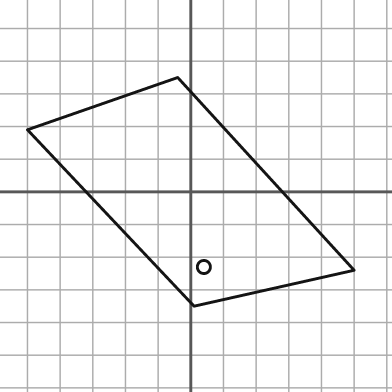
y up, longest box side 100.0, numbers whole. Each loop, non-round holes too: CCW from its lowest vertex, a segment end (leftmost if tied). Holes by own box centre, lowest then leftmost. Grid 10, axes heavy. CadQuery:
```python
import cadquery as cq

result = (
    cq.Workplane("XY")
    .moveTo(1.0, -35.0)
    .lineTo(50.0, -24.0)
    .lineTo(-4.0, 35.0)
    .lineTo(-50.0, 19.0)
    .close()
    .moveTo(4.0, -23.0)
    .circle(2.0)
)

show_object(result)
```